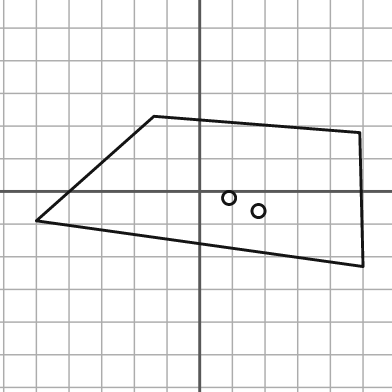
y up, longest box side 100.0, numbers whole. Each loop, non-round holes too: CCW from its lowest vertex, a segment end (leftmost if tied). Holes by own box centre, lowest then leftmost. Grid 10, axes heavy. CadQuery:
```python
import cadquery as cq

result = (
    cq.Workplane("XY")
    .moveTo(50.0, -23.0)
    .lineTo(49.0, 18.0)
    .lineTo(-14.0, 23.0)
    .lineTo(-50.0, -9.0)
    .close()
    .moveTo(18.0, -6.0)
    .circle(2.0)
    .moveTo(9.0, -2.0)
    .circle(2.0)
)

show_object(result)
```